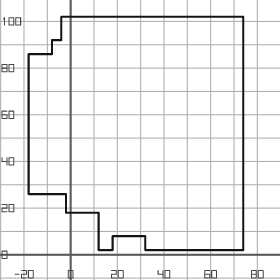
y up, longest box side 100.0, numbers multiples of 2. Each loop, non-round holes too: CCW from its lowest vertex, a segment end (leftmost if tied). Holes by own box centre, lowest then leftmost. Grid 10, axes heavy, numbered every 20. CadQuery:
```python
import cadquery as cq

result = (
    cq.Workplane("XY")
    .moveTo(12.0, 2.0)
    .lineTo(18.0, 2.0)
    .lineTo(18.0, 8.0)
    .lineTo(32.0, 8.0)
    .lineTo(32.0, 2.0)
    .lineTo(74.0, 2.0)
    .lineTo(74.0, 102.0)
    .lineTo(-4.0, 102.0)
    .lineTo(-4.0, 92.0)
    .lineTo(-8.0, 92.0)
    .lineTo(-8.0, 86.0)
    .lineTo(-18.0, 86.0)
    .lineTo(-18.0, 26.0)
    .lineTo(-2.0, 26.0)
    .lineTo(-2.0, 18.0)
    .lineTo(12.0, 18.0)
    .close()
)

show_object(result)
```